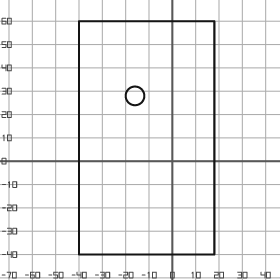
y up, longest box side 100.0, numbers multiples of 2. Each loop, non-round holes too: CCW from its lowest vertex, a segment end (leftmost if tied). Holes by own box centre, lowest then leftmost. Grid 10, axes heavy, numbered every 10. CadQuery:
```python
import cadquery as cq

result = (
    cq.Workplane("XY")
    .moveTo(-40.0, -40.0)
    .lineTo(18.0, -40.0)
    .lineTo(18.0, 60.0)
    .lineTo(-40.0, 60.0)
    .close()
    .moveTo(-16.0, 28.0)
    .circle(4.0)
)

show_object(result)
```